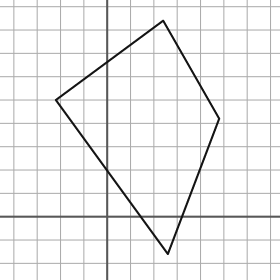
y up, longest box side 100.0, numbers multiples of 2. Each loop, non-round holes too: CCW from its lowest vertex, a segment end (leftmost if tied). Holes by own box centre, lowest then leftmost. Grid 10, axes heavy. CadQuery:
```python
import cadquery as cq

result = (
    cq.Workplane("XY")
    .moveTo(26.0, -16.0)
    .lineTo(48.0, 42.0)
    .lineTo(24.0, 84.0)
    .lineTo(-22.0, 50.0)
    .close()
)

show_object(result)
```